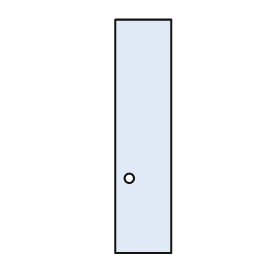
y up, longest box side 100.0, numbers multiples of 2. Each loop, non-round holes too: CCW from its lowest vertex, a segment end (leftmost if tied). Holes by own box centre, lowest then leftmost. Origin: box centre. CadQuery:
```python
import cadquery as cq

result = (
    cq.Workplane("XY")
    .moveTo(-12.0, -50.0)
    .lineTo(12.0, -50.0)
    .lineTo(12.0, 50.0)
    .lineTo(-12.0, 50.0)
    .close()
    .moveTo(-6.0, -18.0)
    .circle(2.0)
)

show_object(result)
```